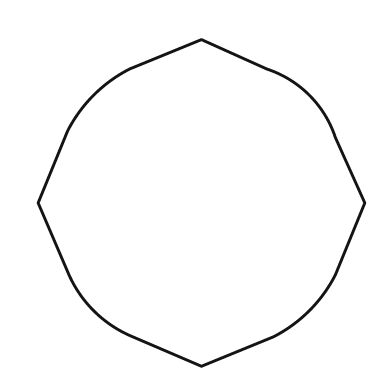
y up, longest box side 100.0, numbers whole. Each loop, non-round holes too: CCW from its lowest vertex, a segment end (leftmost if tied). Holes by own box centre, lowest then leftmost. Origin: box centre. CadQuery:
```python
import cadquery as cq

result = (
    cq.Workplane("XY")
    .moveTo(0.0, -50.0)
    .lineTo(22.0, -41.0)
    .threePointArc((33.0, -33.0), (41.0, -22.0))
    .lineTo(50.0, 0.0)
    .lineTo(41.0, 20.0)
    .threePointArc((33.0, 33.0), (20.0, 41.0))
    .lineTo(0.0, 50.0)
    .lineTo(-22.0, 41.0)
    .threePointArc((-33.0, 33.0), (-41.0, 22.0))
    .lineTo(-50.0, 0.0)
    .lineTo(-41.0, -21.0)
    .threePointArc((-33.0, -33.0), (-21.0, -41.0))
    .close()
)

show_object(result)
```